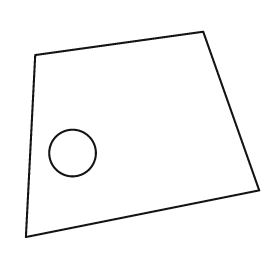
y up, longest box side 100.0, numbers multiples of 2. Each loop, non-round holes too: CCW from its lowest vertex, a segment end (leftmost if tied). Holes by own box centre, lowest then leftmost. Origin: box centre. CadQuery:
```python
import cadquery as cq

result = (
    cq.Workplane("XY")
    .moveTo(-50.0, -44.0)
    .lineTo(50.0, -24.0)
    .lineTo(26.0, 44.0)
    .lineTo(-46.0, 34.0)
    .close()
    .moveTo(-30.0, -8.0)
    .circle(10.0)
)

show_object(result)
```